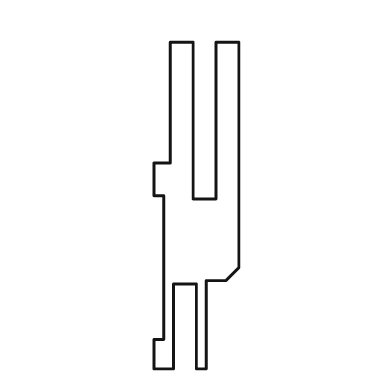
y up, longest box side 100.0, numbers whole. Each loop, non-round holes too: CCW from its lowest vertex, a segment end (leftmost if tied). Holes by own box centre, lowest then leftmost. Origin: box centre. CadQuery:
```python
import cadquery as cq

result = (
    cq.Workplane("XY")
    .moveTo(-13.0, -50.0)
    .lineTo(-7.0, -50.0)
    .lineTo(-7.0, -24.0)
    .lineTo(0.0, -24.0)
    .lineTo(0.0, -50.0)
    .lineTo(3.0, -50.0)
    .lineTo(3.0, -23.0)
    .lineTo(9.0, -23.0)
    .lineTo(13.0, -19.0)
    .lineTo(13.0, 50.0)
    .lineTo(6.0, 50.0)
    .lineTo(6.0, 2.0)
    .lineTo(-1.0, 2.0)
    .lineTo(-1.0, 50.0)
    .lineTo(-8.0, 50.0)
    .lineTo(-8.0, 13.0)
    .lineTo(-13.0, 13.0)
    .lineTo(-13.0, 3.0)
    .lineTo(-10.0, 3.0)
    .lineTo(-10.0, -41.0)
    .lineTo(-13.0, -41.0)
    .close()
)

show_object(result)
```